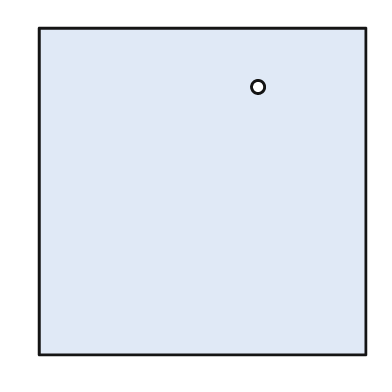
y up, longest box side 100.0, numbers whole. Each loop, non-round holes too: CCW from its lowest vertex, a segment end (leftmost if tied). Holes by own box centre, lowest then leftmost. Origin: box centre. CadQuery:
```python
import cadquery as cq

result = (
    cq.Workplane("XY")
    .moveTo(-50.0, -50.0)
    .lineTo(50.0, -50.0)
    .lineTo(50.0, 50.0)
    .lineTo(-50.0, 50.0)
    .close()
    .moveTo(17.0, 32.0)
    .circle(2.0)
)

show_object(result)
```